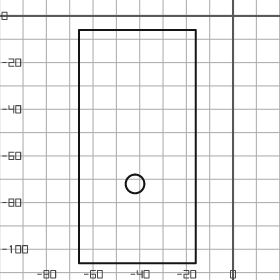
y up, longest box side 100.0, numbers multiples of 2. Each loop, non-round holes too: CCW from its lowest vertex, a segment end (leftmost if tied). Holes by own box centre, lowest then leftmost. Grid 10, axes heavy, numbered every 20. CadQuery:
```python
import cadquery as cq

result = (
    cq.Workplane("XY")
    .moveTo(-66.0, -106.0)
    .lineTo(-16.0, -106.0)
    .lineTo(-16.0, -6.0)
    .lineTo(-66.0, -6.0)
    .close()
    .moveTo(-42.0, -72.0)
    .circle(4.0)
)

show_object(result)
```